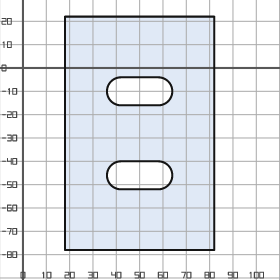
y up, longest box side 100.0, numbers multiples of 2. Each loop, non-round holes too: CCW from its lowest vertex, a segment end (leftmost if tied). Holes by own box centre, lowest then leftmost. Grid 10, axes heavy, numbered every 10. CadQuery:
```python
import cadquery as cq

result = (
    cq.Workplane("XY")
    .moveTo(18.0, -78.0)
    .lineTo(82.0, -78.0)
    .lineTo(82.0, 22.0)
    .lineTo(18.0, 22.0)
    .close()
    .moveTo(42.0, -52.0)
    .lineTo(58.0, -52.0)
    .threePointArc((64.0, -46.0), (58.0, -40.0))
    .lineTo(42.0, -40.0)
    .threePointArc((36.0, -46.0), (42.0, -52.0))
    .close()
    .moveTo(42.0, -16.0)
    .lineTo(58.0, -16.0)
    .threePointArc((64.0, -10.0), (58.0, -4.0))
    .lineTo(42.0, -4.0)
    .threePointArc((36.0, -10.0), (42.0, -16.0))
    .close()
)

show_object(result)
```